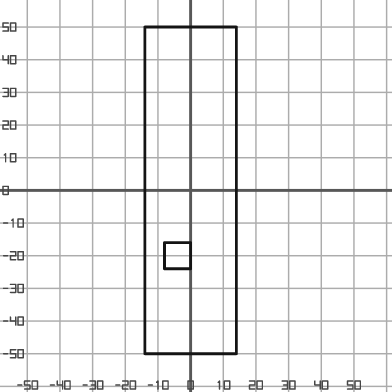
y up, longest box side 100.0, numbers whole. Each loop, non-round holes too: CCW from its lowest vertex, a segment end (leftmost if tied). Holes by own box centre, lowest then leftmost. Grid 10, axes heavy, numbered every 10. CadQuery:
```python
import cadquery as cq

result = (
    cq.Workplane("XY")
    .moveTo(-14.0, -50.0)
    .lineTo(14.0, -50.0)
    .lineTo(14.0, 50.0)
    .lineTo(-14.0, 50.0)
    .close()
    .moveTo(-8.0, -24.0)
    .lineTo(0.0, -24.0)
    .lineTo(0.0, -16.0)
    .lineTo(-8.0, -16.0)
    .close()
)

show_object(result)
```